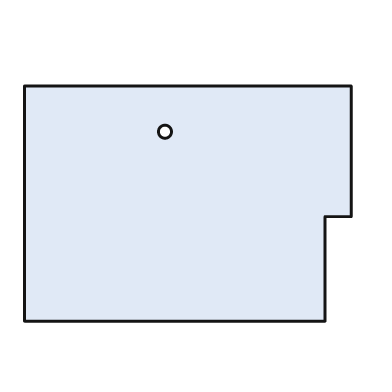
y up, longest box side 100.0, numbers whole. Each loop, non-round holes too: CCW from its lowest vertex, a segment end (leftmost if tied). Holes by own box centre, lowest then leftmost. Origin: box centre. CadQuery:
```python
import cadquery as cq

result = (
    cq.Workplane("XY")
    .moveTo(-50.0, -36.0)
    .lineTo(42.0, -36.0)
    .lineTo(42.0, -4.0)
    .lineTo(50.0, -4.0)
    .lineTo(50.0, 36.0)
    .lineTo(-50.0, 36.0)
    .close()
    .moveTo(-7.0, 22.0)
    .circle(2.0)
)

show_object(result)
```